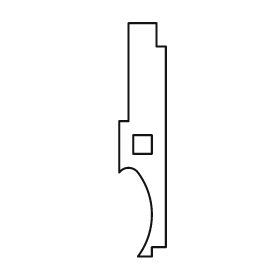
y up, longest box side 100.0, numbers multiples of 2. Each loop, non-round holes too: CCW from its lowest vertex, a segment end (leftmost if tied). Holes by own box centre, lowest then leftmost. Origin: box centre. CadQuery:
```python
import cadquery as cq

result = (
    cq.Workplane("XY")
    .moveTo(-2.0, -50.0)
    .lineTo(4.0, -50.0)
    .lineTo(4.0, -46.0)
    .lineTo(10.0, -46.0)
    .lineTo(10.0, 40.0)
    .lineTo(6.0, 40.0)
    .lineTo(6.0, 50.0)
    .lineTo(-6.0, 50.0)
    .lineTo(-6.0, 8.0)
    .lineTo(-10.0, 8.0)
    .lineTo(-10.0, -14.0)
    .threePointArc((-6.0, -12.0), (-2.0, -14.0))
    .threePointArc((4.0, -32.0), (-2.0, -50.0))
    .close()
    .moveTo(-4.0, -6.0)
    .lineTo(4.0, -6.0)
    .lineTo(4.0, 2.0)
    .lineTo(-4.0, 2.0)
    .close()
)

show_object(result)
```